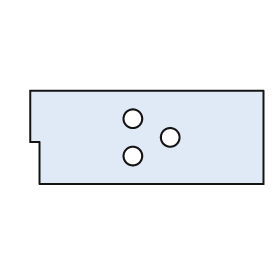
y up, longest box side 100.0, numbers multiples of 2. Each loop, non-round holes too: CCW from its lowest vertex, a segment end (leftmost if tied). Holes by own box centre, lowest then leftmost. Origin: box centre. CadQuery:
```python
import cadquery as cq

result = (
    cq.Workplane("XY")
    .moveTo(-46.0, -20.0)
    .lineTo(50.0, -20.0)
    .lineTo(50.0, 20.0)
    .lineTo(-50.0, 20.0)
    .lineTo(-50.0, -2.0)
    .lineTo(-46.0, -2.0)
    .close()
    .moveTo(-6.0, -8.0)
    .circle(4.0)
    .moveTo(10.0, 0.0)
    .circle(4.0)
    .moveTo(-6.0, 8.0)
    .circle(4.0)
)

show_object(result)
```